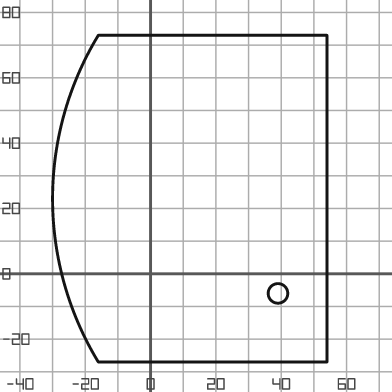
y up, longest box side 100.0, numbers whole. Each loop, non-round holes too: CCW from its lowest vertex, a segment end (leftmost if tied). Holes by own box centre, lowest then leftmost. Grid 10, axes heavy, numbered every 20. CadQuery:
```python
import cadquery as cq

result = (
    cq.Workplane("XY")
    .moveTo(-16.0, -27.0)
    .lineTo(54.0, -27.0)
    .lineTo(54.0, 73.0)
    .lineTo(-16.0, 73.0)
    .threePointArc((-30.0, 23.0), (-16.0, -27.0))
    .close()
    .moveTo(39.0, -6.0)
    .circle(3.0)
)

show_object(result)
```